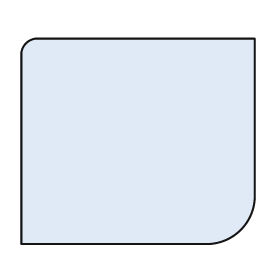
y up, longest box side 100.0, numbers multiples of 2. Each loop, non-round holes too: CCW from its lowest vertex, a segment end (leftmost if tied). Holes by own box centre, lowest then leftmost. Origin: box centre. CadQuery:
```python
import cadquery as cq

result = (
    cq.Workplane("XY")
    .moveTo(-50.0, -44.0)
    .lineTo(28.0, -44.0)
    .threePointArc((44.0, -38.0), (50.0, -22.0))
    .lineTo(50.0, 44.0)
    .lineTo(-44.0, 44.0)
    .threePointArc((-48.0, 42.0), (-50.0, 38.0))
    .close()
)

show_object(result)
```